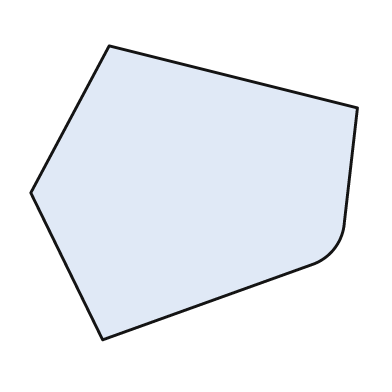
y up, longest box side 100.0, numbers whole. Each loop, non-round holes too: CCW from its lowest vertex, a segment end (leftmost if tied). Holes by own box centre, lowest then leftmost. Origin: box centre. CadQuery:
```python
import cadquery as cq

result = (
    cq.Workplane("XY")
    .moveTo(-28.0, -45.0)
    .lineTo(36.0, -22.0)
    .threePointArc((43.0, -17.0), (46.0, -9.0))
    .lineTo(50.0, 26.0)
    .lineTo(-26.0, 45.0)
    .lineTo(-50.0, 0.0)
    .close()
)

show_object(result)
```